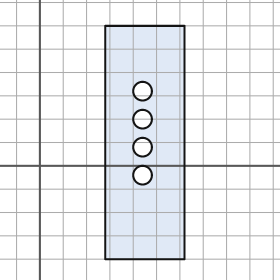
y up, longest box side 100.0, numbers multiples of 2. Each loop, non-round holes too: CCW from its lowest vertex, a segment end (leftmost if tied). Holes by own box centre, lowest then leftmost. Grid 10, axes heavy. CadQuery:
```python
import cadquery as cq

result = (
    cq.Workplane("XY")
    .moveTo(28.0, -40.0)
    .lineTo(62.0, -40.0)
    .lineTo(62.0, 60.0)
    .lineTo(28.0, 60.0)
    .close()
    .moveTo(44.0, -4.0)
    .circle(4.0)
    .moveTo(44.0, 8.0)
    .circle(4.0)
    .moveTo(44.0, 20.0)
    .circle(4.0)
    .moveTo(44.0, 32.0)
    .circle(4.0)
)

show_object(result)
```